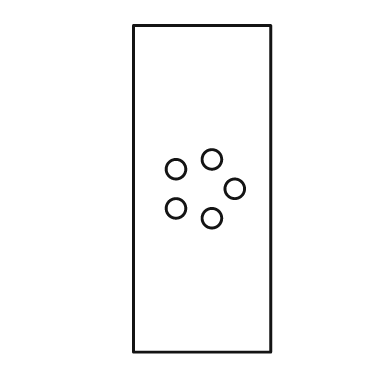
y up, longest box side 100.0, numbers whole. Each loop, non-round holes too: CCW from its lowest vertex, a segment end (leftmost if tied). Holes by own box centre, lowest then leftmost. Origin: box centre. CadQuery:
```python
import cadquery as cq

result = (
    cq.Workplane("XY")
    .moveTo(-21.0, -50.0)
    .lineTo(21.0, -50.0)
    .lineTo(21.0, 50.0)
    .lineTo(-21.0, 50.0)
    .close()
    .moveTo(3.0, -9.0)
    .circle(3.0)
    .moveTo(-8.0, -6.0)
    .circle(3.0)
    .moveTo(10.0, 0.0)
    .circle(3.0)
    .moveTo(-8.0, 6.0)
    .circle(3.0)
    .moveTo(3.0, 9.0)
    .circle(3.0)
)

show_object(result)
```